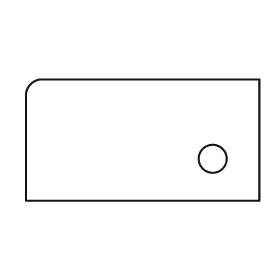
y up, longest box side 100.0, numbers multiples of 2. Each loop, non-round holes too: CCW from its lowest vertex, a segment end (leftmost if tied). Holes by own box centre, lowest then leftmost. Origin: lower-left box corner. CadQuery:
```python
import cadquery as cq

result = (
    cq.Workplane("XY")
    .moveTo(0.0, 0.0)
    .lineTo(100.0, 0.0)
    .lineTo(100.0, 52.0)
    .lineTo(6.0, 52.0)
    .threePointArc((2.0, 50.0), (0.0, 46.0))
    .close()
    .moveTo(80.0, 18.0)
    .circle(6.0)
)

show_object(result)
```